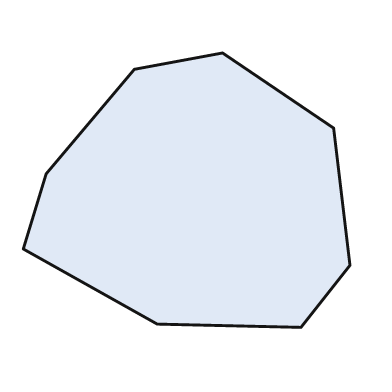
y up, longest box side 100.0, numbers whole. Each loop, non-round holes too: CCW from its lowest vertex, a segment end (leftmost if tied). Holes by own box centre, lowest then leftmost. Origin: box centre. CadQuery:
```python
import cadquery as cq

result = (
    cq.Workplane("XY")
    .moveTo(35.0, -42.0)
    .lineTo(50.0, -23.0)
    .lineTo(45.0, 19.0)
    .lineTo(11.0, 42.0)
    .lineTo(-16.0, 37.0)
    .lineTo(-43.0, 5.0)
    .lineTo(-50.0, -18.0)
    .lineTo(-9.0, -41.0)
    .close()
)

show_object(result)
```